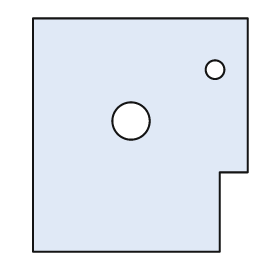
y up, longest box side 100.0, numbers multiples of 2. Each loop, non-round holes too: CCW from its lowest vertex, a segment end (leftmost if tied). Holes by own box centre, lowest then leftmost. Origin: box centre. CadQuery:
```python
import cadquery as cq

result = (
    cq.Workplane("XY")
    .moveTo(-46.0, -50.0)
    .lineTo(34.0, -50.0)
    .lineTo(34.0, -16.0)
    .lineTo(46.0, -16.0)
    .lineTo(46.0, 50.0)
    .lineTo(-46.0, 50.0)
    .close()
    .moveTo(-4.0, 6.0)
    .circle(8.0)
    .moveTo(32.0, 28.0)
    .circle(4.0)
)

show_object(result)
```